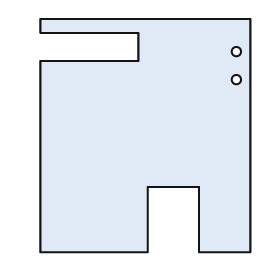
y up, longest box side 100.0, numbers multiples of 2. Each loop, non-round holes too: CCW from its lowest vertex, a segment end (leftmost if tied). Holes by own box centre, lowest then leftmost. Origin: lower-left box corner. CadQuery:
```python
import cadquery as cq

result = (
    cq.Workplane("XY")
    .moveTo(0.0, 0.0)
    .lineTo(46.0, 0.0)
    .lineTo(46.0, 28.0)
    .lineTo(68.0, 28.0)
    .lineTo(68.0, 0.0)
    .lineTo(90.0, 0.0)
    .lineTo(90.0, 100.0)
    .lineTo(0.0, 100.0)
    .lineTo(0.0, 94.0)
    .lineTo(42.0, 94.0)
    .lineTo(42.0, 82.0)
    .lineTo(0.0, 82.0)
    .close()
    .moveTo(84.0, 74.0)
    .circle(2.0)
    .moveTo(84.0, 86.0)
    .circle(2.0)
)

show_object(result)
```